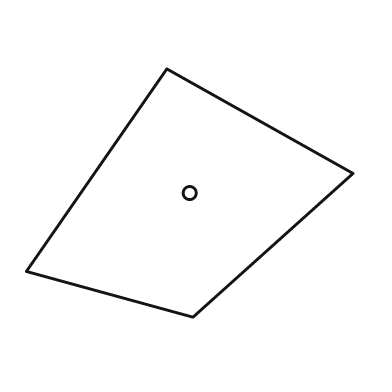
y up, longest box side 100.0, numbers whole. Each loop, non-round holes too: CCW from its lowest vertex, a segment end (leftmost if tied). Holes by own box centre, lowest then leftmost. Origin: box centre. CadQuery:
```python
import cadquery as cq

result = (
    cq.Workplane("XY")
    .moveTo(1.0, -38.0)
    .lineTo(50.0, 6.0)
    .lineTo(-7.0, 38.0)
    .lineTo(-50.0, -24.0)
    .close()
    .moveTo(0.0, 0.0)
    .circle(2.0)
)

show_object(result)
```